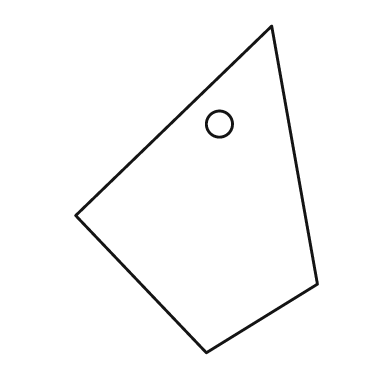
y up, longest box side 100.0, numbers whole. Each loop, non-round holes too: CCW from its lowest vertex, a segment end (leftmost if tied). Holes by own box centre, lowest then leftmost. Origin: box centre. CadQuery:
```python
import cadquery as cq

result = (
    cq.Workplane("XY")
    .moveTo(3.0, -50.0)
    .lineTo(37.0, -29.0)
    .lineTo(23.0, 50.0)
    .lineTo(-37.0, -8.0)
    .close()
    .moveTo(7.0, 20.0)
    .circle(4.0)
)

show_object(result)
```